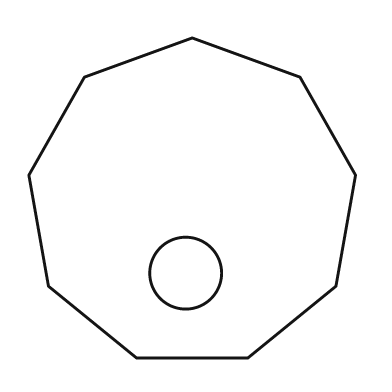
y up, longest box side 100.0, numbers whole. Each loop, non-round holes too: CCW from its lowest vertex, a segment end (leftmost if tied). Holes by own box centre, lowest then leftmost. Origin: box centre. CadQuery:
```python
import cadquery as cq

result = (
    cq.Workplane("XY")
    .moveTo(-17.0, -49.0)
    .lineTo(17.0, -49.0)
    .lineTo(44.0, -27.0)
    .lineTo(50.0, 7.0)
    .lineTo(33.0, 37.0)
    .lineTo(0.0, 49.0)
    .lineTo(-33.0, 37.0)
    .lineTo(-50.0, 7.0)
    .lineTo(-44.0, -27.0)
    .close()
    .moveTo(-2.0, -23.0)
    .circle(11.0)
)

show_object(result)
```